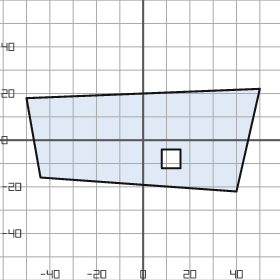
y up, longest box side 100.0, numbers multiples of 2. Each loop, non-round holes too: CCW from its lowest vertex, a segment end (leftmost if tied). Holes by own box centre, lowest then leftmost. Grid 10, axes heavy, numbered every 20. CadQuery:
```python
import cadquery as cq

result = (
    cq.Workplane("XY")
    .moveTo(40.0, -22.0)
    .lineTo(50.0, 22.0)
    .lineTo(-50.0, 18.0)
    .lineTo(-44.0, -16.0)
    .close()
    .moveTo(8.0, -12.0)
    .lineTo(16.0, -12.0)
    .lineTo(16.0, -4.0)
    .lineTo(8.0, -4.0)
    .close()
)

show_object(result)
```